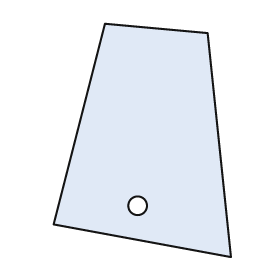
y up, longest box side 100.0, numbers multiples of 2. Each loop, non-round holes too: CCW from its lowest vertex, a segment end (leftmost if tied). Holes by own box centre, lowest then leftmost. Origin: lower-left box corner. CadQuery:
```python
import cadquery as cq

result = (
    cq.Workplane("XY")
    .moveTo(76.0, 0.0)
    .lineTo(66.0, 96.0)
    .lineTo(22.0, 100.0)
    .lineTo(0.0, 14.0)
    .close()
    .moveTo(36.0, 22.0)
    .circle(4.0)
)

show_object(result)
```